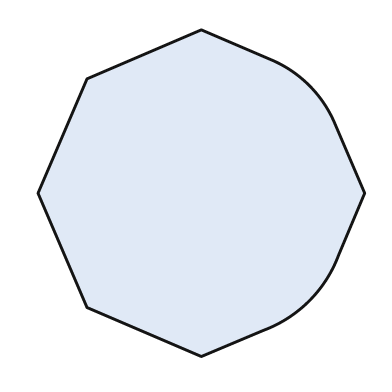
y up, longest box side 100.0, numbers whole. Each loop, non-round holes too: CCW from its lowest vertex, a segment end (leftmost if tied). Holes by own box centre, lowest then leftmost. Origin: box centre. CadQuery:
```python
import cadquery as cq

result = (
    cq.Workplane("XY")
    .moveTo(0.0, -50.0)
    .lineTo(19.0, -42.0)
    .threePointArc((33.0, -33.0), (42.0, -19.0))
    .lineTo(50.0, 0.0)
    .lineTo(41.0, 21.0)
    .threePointArc((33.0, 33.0), (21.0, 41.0))
    .lineTo(0.0, 50.0)
    .lineTo(-35.0, 35.0)
    .lineTo(-50.0, 0.0)
    .lineTo(-35.0, -35.0)
    .close()
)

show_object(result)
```